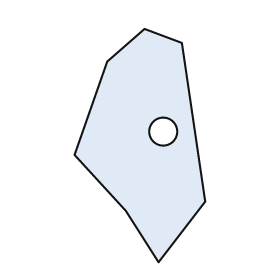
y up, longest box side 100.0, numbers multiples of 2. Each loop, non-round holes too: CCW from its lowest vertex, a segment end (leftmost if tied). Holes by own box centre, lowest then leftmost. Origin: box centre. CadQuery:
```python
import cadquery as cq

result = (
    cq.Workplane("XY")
    .moveTo(8.0, -50.0)
    .lineTo(28.0, -24.0)
    .lineTo(18.0, 44.0)
    .lineTo(2.0, 50.0)
    .lineTo(-14.0, 36.0)
    .lineTo(-28.0, -4.0)
    .lineTo(-6.0, -28.0)
    .close()
    .moveTo(10.0, 6.0)
    .circle(6.0)
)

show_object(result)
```